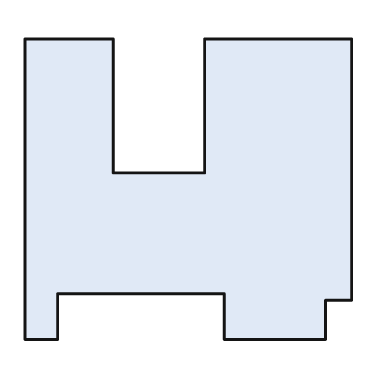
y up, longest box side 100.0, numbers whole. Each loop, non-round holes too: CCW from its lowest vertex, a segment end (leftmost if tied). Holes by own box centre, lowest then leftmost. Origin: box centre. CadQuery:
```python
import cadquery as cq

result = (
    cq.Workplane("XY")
    .moveTo(-50.0, -46.0)
    .lineTo(-40.0, -46.0)
    .lineTo(-40.0, -32.0)
    .lineTo(11.0, -32.0)
    .lineTo(11.0, -46.0)
    .lineTo(42.0, -46.0)
    .lineTo(42.0, -34.0)
    .lineTo(50.0, -34.0)
    .lineTo(50.0, 46.0)
    .lineTo(5.0, 46.0)
    .lineTo(5.0, 5.0)
    .lineTo(-23.0, 5.0)
    .lineTo(-23.0, 46.0)
    .lineTo(-50.0, 46.0)
    .close()
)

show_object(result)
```